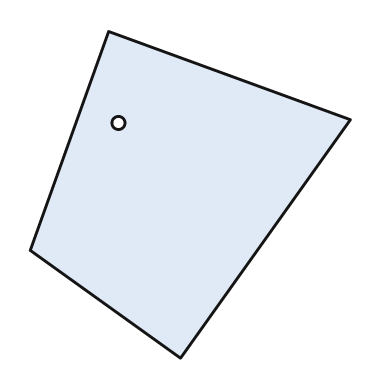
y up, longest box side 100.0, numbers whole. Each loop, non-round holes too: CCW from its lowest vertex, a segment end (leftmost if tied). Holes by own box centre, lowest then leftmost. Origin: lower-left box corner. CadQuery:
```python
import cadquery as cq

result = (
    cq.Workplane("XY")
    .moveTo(46.0, 0.0)
    .lineTo(98.0, 73.0)
    .lineTo(24.0, 100.0)
    .lineTo(0.0, 33.0)
    .close()
    .moveTo(27.0, 72.0)
    .circle(2.0)
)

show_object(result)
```